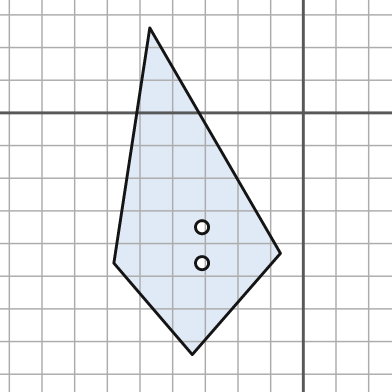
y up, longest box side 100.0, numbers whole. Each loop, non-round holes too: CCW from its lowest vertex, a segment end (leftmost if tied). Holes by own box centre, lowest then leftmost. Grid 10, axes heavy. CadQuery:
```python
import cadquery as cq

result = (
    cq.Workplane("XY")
    .moveTo(-34.0, -74.0)
    .lineTo(-7.0, -43.0)
    .lineTo(-47.0, 26.0)
    .lineTo(-58.0, -46.0)
    .close()
    .moveTo(-31.0, -46.0)
    .circle(2.0)
    .moveTo(-31.0, -35.0)
    .circle(2.0)
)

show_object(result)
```